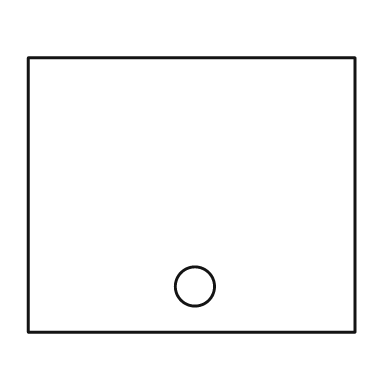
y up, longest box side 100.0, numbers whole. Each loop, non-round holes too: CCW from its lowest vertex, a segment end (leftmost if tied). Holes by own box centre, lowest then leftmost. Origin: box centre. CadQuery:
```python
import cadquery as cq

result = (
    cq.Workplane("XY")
    .moveTo(-50.0, -42.0)
    .lineTo(50.0, -42.0)
    .lineTo(50.0, 42.0)
    .lineTo(-50.0, 42.0)
    .close()
    .moveTo(1.0, -28.0)
    .circle(6.0)
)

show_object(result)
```